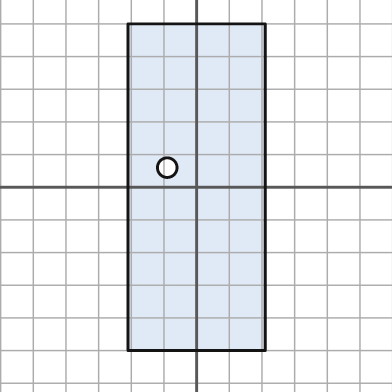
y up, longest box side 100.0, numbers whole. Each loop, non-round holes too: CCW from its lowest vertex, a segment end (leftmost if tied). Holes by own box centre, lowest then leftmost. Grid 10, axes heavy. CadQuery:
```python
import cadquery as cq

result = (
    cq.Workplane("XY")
    .moveTo(-21.0, -50.0)
    .lineTo(21.0, -50.0)
    .lineTo(21.0, 50.0)
    .lineTo(-21.0, 50.0)
    .close()
    .moveTo(-9.0, 6.0)
    .circle(3.0)
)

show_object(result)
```